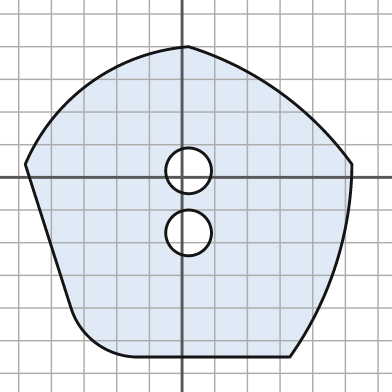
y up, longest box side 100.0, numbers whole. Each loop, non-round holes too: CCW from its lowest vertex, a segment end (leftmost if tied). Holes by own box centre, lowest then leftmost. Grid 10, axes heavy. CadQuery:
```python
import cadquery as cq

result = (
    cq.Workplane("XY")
    .moveTo(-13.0, -55.0)
    .lineTo(33.0, -55.0)
    .threePointArc((47.0, -27.0), (52.0, 4.0))
    .threePointArc((30.0, 26.0), (2.0, 40.0))
    .threePointArc((-28.0, 29.0), (-48.0, 4.0))
    .lineTo(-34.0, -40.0)
    .threePointArc((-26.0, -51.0), (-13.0, -55.0))
    .close()
    .moveTo(2.0, -17.0)
    .circle(7.0)
    .moveTo(2.0, 2.0)
    .circle(7.0)
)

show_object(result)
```